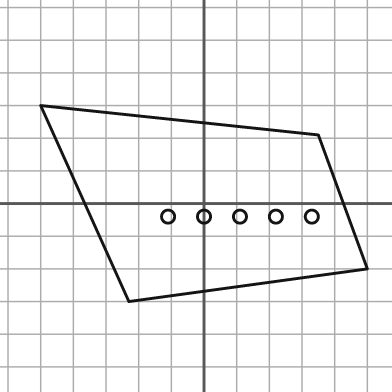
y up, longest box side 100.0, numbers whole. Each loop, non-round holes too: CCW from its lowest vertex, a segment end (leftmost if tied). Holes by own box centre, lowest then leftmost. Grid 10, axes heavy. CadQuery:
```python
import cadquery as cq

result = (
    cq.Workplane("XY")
    .moveTo(-23.0, -30.0)
    .lineTo(50.0, -20.0)
    .lineTo(35.0, 21.0)
    .lineTo(-50.0, 30.0)
    .close()
    .moveTo(-11.0, -4.0)
    .circle(2.0)
    .moveTo(0.0, -4.0)
    .circle(2.0)
    .moveTo(11.0, -4.0)
    .circle(2.0)
    .moveTo(22.0, -4.0)
    .circle(2.0)
    .moveTo(33.0, -4.0)
    .circle(2.0)
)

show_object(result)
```